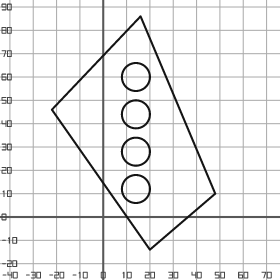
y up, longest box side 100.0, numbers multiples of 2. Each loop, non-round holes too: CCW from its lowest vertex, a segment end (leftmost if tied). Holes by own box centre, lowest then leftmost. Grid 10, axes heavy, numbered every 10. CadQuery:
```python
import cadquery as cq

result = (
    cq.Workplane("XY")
    .moveTo(20.0, -14.0)
    .lineTo(48.0, 10.0)
    .lineTo(16.0, 86.0)
    .lineTo(-22.0, 46.0)
    .close()
    .moveTo(14.0, 12.0)
    .circle(6.0)
    .moveTo(14.0, 28.0)
    .circle(6.0)
    .moveTo(14.0, 44.0)
    .circle(6.0)
    .moveTo(14.0, 60.0)
    .circle(6.0)
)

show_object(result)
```